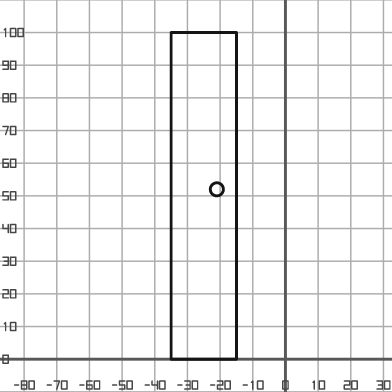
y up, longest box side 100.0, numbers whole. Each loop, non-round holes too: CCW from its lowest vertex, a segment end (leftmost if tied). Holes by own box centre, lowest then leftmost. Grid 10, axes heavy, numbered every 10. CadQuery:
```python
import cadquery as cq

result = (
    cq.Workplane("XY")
    .moveTo(-35.0, 0.0)
    .lineTo(-15.0, 0.0)
    .lineTo(-15.0, 100.0)
    .lineTo(-35.0, 100.0)
    .close()
    .moveTo(-21.0, 52.0)
    .circle(2.0)
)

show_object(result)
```